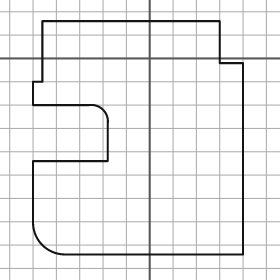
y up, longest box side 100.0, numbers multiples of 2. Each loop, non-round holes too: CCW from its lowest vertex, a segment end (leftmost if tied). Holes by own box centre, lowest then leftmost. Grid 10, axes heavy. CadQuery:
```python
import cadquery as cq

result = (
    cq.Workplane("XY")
    .moveTo(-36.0, -84.0)
    .lineTo(40.0, -84.0)
    .lineTo(40.0, -2.0)
    .lineTo(30.0, -2.0)
    .lineTo(30.0, 16.0)
    .lineTo(-46.0, 16.0)
    .lineTo(-46.0, -10.0)
    .lineTo(-50.0, -10.0)
    .lineTo(-50.0, -20.0)
    .lineTo(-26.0, -20.0)
    .threePointArc((-20.0, -22.0), (-18.0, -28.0))
    .lineTo(-18.0, -44.0)
    .lineTo(-50.0, -44.0)
    .lineTo(-50.0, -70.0)
    .threePointArc((-46.0, -80.0), (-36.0, -84.0))
    .close()
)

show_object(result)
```